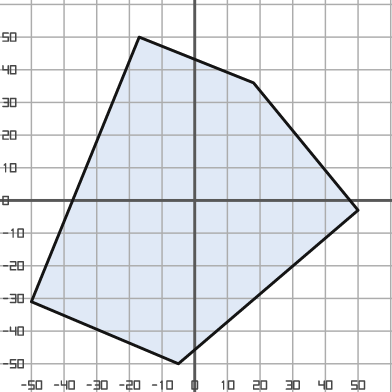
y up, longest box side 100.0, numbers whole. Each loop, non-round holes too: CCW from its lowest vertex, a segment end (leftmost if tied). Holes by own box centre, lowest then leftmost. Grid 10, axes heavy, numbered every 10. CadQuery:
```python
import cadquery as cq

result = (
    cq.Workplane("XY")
    .moveTo(-5.0, -50.0)
    .lineTo(50.0, -3.0)
    .lineTo(18.0, 36.0)
    .lineTo(-17.0, 50.0)
    .lineTo(-50.0, -31.0)
    .close()
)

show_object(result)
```